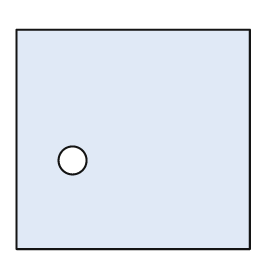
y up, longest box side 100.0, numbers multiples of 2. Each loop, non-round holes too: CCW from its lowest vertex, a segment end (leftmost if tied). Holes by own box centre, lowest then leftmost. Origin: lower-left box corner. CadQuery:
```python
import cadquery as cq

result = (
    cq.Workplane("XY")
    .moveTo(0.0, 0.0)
    .lineTo(100.0, 0.0)
    .lineTo(100.0, 94.0)
    .lineTo(0.0, 94.0)
    .close()
    .moveTo(24.0, 38.0)
    .circle(6.0)
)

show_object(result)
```